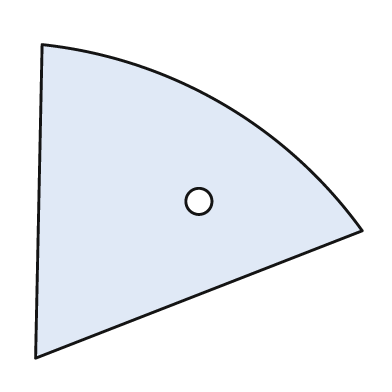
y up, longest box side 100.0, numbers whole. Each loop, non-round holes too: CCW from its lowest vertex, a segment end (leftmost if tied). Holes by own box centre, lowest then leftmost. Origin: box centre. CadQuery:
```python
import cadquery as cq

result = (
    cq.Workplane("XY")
    .moveTo(-50.0, -48.0)
    .lineTo(50.0, -9.0)
    .threePointArc((7.0, 30.0), (-48.0, 48.0))
    .close()
    .moveTo(0.0, 0.0)
    .circle(4.0)
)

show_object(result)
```